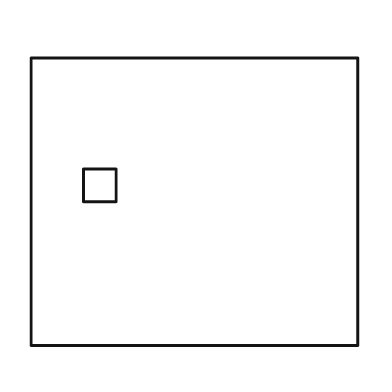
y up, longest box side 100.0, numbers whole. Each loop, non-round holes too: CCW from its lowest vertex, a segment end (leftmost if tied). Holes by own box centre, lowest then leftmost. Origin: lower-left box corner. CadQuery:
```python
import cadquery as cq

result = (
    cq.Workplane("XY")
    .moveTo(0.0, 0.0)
    .lineTo(100.0, 0.0)
    .lineTo(100.0, 88.0)
    .lineTo(0.0, 88.0)
    .close()
    .moveTo(16.0, 44.0)
    .lineTo(26.0, 44.0)
    .lineTo(26.0, 54.0)
    .lineTo(16.0, 54.0)
    .close()
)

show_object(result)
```